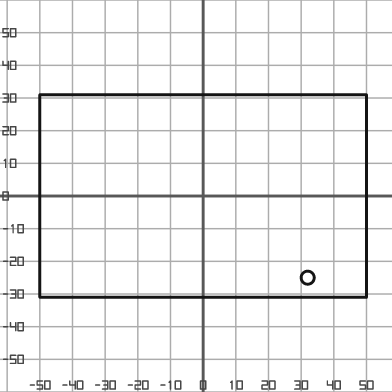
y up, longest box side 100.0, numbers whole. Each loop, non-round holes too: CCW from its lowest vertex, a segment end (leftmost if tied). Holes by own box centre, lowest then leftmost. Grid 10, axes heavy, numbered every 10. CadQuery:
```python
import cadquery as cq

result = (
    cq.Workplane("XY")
    .moveTo(-50.0, -31.0)
    .lineTo(50.0, -31.0)
    .lineTo(50.0, 31.0)
    .lineTo(-50.0, 31.0)
    .close()
    .moveTo(32.0, -25.0)
    .circle(2.0)
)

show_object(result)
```